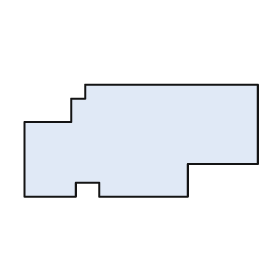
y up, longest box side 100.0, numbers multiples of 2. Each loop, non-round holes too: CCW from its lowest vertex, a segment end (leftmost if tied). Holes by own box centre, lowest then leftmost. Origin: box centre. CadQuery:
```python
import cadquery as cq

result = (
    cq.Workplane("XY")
    .moveTo(-50.0, -24.0)
    .lineTo(-28.0, -24.0)
    .lineTo(-28.0, -18.0)
    .lineTo(-18.0, -18.0)
    .lineTo(-18.0, -24.0)
    .lineTo(20.0, -24.0)
    .lineTo(20.0, -10.0)
    .lineTo(50.0, -10.0)
    .lineTo(50.0, 24.0)
    .lineTo(-24.0, 24.0)
    .lineTo(-24.0, 18.0)
    .lineTo(-30.0, 18.0)
    .lineTo(-30.0, 8.0)
    .lineTo(-50.0, 8.0)
    .close()
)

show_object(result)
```